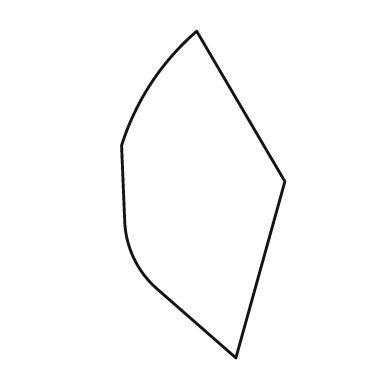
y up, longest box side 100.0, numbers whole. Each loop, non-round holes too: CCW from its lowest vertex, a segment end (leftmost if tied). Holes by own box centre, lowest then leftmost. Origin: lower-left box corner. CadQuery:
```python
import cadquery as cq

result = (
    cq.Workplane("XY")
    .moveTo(35.0, 0.0)
    .lineTo(50.0, 54.0)
    .lineTo(23.0, 100.0)
    .threePointArc((9.0, 84.0), (0.0, 65.0))
    .lineTo(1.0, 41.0)
    .threePointArc((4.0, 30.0), (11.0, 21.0))
    .close()
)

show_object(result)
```